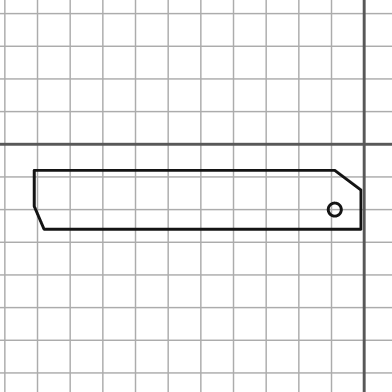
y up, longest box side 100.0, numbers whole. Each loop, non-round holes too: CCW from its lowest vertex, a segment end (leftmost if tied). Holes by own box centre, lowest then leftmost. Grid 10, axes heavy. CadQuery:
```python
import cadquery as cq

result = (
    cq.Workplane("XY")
    .moveTo(-98.0, -26.0)
    .lineTo(-1.0, -26.0)
    .lineTo(-1.0, -14.0)
    .lineTo(-9.0, -8.0)
    .lineTo(-101.0, -8.0)
    .lineTo(-101.0, -19.0)
    .close()
    .moveTo(-9.0, -20.0)
    .circle(2.0)
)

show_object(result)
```